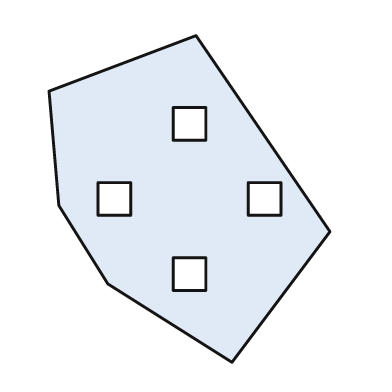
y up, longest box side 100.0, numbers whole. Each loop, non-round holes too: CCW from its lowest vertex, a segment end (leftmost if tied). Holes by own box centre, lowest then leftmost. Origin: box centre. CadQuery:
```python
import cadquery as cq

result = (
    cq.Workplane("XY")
    .moveTo(13.0, -50.0)
    .lineTo(43.0, -10.0)
    .lineTo(2.0, 50.0)
    .lineTo(-43.0, 33.0)
    .lineTo(-40.0, -2.0)
    .lineTo(-25.0, -26.0)
    .close()
    .moveTo(-5.0, -28.0)
    .lineTo(5.0, -28.0)
    .lineTo(5.0, -18.0)
    .lineTo(-5.0, -18.0)
    .close()
    .moveTo(-28.0, -5.0)
    .lineTo(-18.0, -5.0)
    .lineTo(-18.0, 5.0)
    .lineTo(-28.0, 5.0)
    .close()
    .moveTo(18.0, -5.0)
    .lineTo(28.0, -5.0)
    .lineTo(28.0, 5.0)
    .lineTo(18.0, 5.0)
    .close()
    .moveTo(-5.0, 18.0)
    .lineTo(5.0, 18.0)
    .lineTo(5.0, 28.0)
    .lineTo(-5.0, 28.0)
    .close()
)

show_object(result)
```